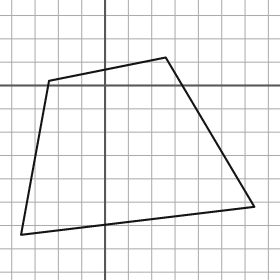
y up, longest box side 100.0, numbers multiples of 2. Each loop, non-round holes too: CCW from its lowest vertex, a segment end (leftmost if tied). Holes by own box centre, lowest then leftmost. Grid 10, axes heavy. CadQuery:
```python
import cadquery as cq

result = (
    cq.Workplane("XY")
    .moveTo(-36.0, -64.0)
    .lineTo(64.0, -52.0)
    .lineTo(26.0, 12.0)
    .lineTo(-24.0, 2.0)
    .close()
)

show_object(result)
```